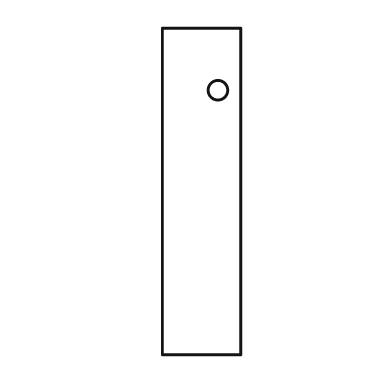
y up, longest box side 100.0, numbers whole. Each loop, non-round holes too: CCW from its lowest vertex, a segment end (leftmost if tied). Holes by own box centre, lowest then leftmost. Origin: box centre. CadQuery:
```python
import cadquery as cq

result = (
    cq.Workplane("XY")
    .moveTo(-12.0, -50.0)
    .lineTo(12.0, -50.0)
    .lineTo(12.0, 50.0)
    .lineTo(-12.0, 50.0)
    .close()
    .moveTo(5.0, 31.0)
    .circle(3.0)
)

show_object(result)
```